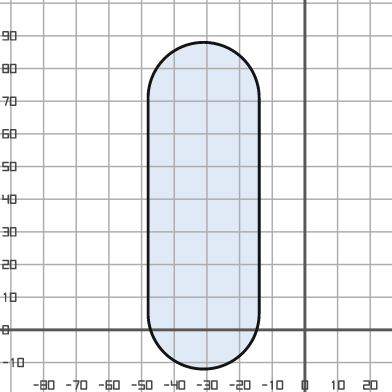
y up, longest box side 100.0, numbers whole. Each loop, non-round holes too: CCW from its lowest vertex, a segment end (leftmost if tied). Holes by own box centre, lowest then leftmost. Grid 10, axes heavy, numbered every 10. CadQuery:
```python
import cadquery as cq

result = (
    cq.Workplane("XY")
    .moveTo(-48.0, 5.0)
    .threePointArc((-31.0, -12.0), (-14.0, 5.0))
    .lineTo(-14.0, 71.0)
    .threePointArc((-31.0, 88.0), (-48.0, 71.0))
    .close()
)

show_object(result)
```